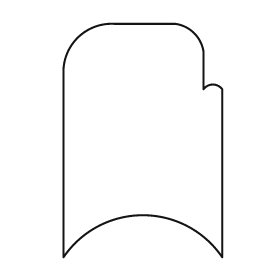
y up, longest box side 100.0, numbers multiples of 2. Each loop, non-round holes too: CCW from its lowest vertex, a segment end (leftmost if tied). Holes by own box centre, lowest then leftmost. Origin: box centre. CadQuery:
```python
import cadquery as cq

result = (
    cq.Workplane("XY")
    .moveTo(-34.0, -50.0)
    .threePointArc((0.0, -32.0), (34.0, -50.0))
    .lineTo(34.0, 22.0)
    .threePointArc((30.0, 24.0), (26.0, 22.0))
    .lineTo(26.0, 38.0)
    .threePointArc((22.0, 46.0), (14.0, 50.0))
    .lineTo(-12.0, 50.0)
    .threePointArc((-28.0, 44.0), (-34.0, 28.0))
    .close()
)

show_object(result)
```